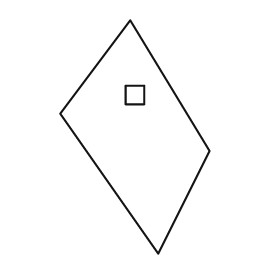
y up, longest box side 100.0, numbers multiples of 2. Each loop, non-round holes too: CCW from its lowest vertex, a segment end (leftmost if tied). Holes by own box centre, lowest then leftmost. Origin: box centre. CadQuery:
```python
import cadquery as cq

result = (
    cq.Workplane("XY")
    .moveTo(10.0, -50.0)
    .lineTo(32.0, -6.0)
    .lineTo(-2.0, 50.0)
    .lineTo(-32.0, 10.0)
    .close()
    .moveTo(-4.0, 14.0)
    .lineTo(4.0, 14.0)
    .lineTo(4.0, 22.0)
    .lineTo(-4.0, 22.0)
    .close()
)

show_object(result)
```